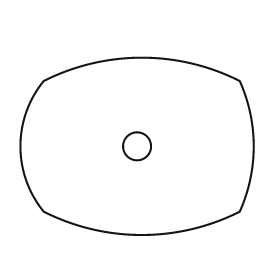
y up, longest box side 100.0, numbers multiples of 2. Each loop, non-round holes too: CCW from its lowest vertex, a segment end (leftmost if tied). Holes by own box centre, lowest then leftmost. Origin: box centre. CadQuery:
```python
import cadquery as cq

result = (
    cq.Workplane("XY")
    .moveTo(-40.0, -28.0)
    .threePointArc((2.0, -38.0), (44.0, -28.0))
    .threePointArc((50.0, 0.0), (44.0, 28.0))
    .threePointArc((2.0, 38.0), (-40.0, 28.0))
    .threePointArc((-50.0, 0.0), (-40.0, -28.0))
    .close()
    .moveTo(0.0, 0.0)
    .circle(6.0)
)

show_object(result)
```